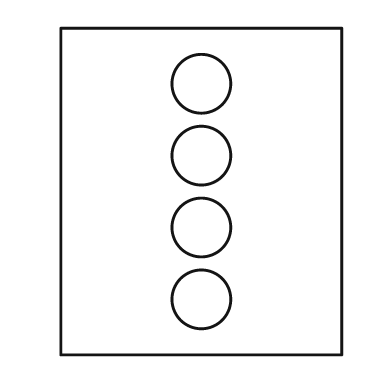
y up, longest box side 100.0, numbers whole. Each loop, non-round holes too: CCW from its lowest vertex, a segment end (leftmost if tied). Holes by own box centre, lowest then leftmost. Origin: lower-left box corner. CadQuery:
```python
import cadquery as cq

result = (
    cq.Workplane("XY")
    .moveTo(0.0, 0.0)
    .lineTo(86.0, 0.0)
    .lineTo(86.0, 100.0)
    .lineTo(0.0, 100.0)
    .close()
    .moveTo(43.0, 17.0)
    .circle(9.0)
    .moveTo(43.0, 39.0)
    .circle(9.0)
    .moveTo(43.0, 61.0)
    .circle(9.0)
    .moveTo(43.0, 83.0)
    .circle(9.0)
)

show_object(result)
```